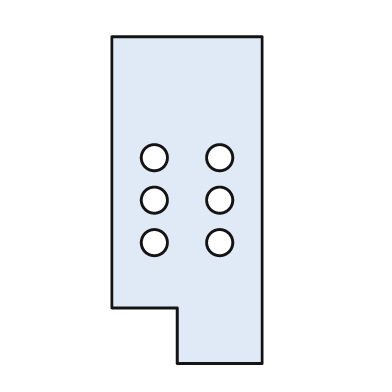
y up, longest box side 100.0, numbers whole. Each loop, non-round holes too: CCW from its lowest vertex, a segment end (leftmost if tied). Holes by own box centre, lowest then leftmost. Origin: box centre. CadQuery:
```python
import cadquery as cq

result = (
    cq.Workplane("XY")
    .moveTo(-3.0, -50.0)
    .lineTo(23.0, -50.0)
    .lineTo(23.0, 50.0)
    .lineTo(-23.0, 50.0)
    .lineTo(-23.0, -33.0)
    .lineTo(-3.0, -33.0)
    .close()
    .moveTo(-10.0, -13.0)
    .circle(4.0)
    .moveTo(10.0, -13.0)
    .circle(4.0)
    .moveTo(-10.0, 0.0)
    .circle(4.0)
    .moveTo(10.0, 0.0)
    .circle(4.0)
    .moveTo(-10.0, 13.0)
    .circle(4.0)
    .moveTo(10.0, 13.0)
    .circle(4.0)
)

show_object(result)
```